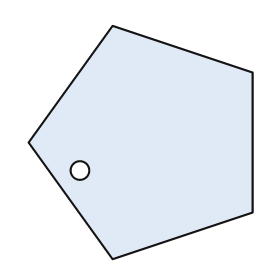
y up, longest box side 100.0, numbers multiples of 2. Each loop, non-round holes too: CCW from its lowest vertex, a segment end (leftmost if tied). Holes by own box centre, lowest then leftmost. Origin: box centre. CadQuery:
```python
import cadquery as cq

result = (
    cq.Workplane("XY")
    .moveTo(-12.0, -50.0)
    .lineTo(48.0, -30.0)
    .lineTo(48.0, 30.0)
    .lineTo(-12.0, 50.0)
    .lineTo(-48.0, 0.0)
    .close()
    .moveTo(-26.0, -12.0)
    .circle(4.0)
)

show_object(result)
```